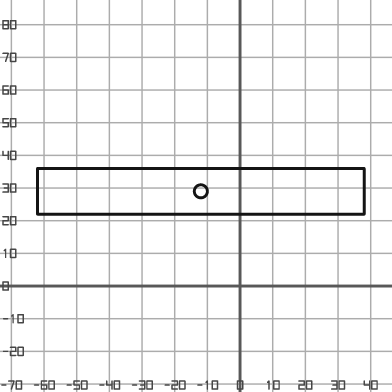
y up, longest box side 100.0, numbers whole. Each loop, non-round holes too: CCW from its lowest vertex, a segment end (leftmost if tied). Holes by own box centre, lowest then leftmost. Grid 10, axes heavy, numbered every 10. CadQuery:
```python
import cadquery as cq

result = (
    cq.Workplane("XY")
    .moveTo(-62.0, 22.0)
    .lineTo(38.0, 22.0)
    .lineTo(38.0, 36.0)
    .lineTo(-62.0, 36.0)
    .close()
    .moveTo(-12.0, 29.0)
    .circle(2.0)
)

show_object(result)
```